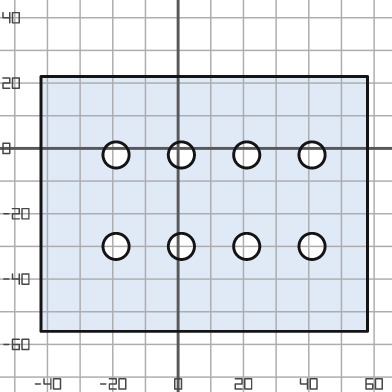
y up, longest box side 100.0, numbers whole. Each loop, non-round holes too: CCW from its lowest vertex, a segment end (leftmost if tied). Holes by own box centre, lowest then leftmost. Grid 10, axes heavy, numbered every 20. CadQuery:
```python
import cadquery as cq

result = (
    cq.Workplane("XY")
    .moveTo(-42.0, -56.0)
    .lineTo(58.0, -56.0)
    .lineTo(58.0, 22.0)
    .lineTo(-42.0, 22.0)
    .close()
    .moveTo(-19.0, -30.0)
    .circle(4.0)
    .moveTo(1.0, -30.0)
    .circle(4.0)
    .moveTo(21.0, -30.0)
    .circle(4.0)
    .moveTo(41.0, -30.0)
    .circle(4.0)
    .moveTo(-19.0, -2.0)
    .circle(4.0)
    .moveTo(1.0, -2.0)
    .circle(4.0)
    .moveTo(21.0, -2.0)
    .circle(4.0)
    .moveTo(41.0, -2.0)
    .circle(4.0)
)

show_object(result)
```